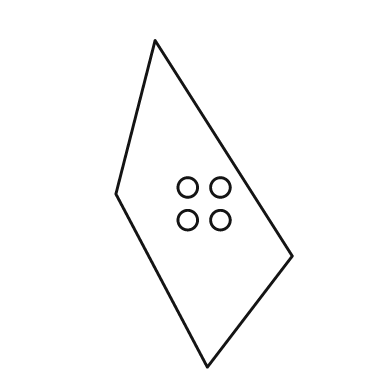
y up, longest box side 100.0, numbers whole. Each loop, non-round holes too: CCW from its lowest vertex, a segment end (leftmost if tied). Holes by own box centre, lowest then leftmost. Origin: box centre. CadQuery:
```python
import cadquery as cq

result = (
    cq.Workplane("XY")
    .moveTo(1.0, -50.0)
    .lineTo(27.0, -16.0)
    .lineTo(-15.0, 50.0)
    .lineTo(-27.0, 3.0)
    .close()
    .moveTo(-5.0, -5.0)
    .circle(3.0)
    .moveTo(5.0, -5.0)
    .circle(3.0)
    .moveTo(-5.0, 5.0)
    .circle(3.0)
    .moveTo(5.0, 5.0)
    .circle(3.0)
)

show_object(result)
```